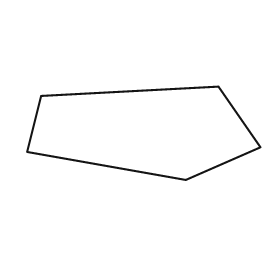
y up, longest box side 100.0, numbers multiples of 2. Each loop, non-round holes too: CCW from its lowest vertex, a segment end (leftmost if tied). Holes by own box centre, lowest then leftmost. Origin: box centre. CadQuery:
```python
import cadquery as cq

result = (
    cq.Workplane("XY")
    .moveTo(18.0, -20.0)
    .lineTo(50.0, -6.0)
    .lineTo(32.0, 20.0)
    .lineTo(-44.0, 16.0)
    .lineTo(-50.0, -8.0)
    .close()
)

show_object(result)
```